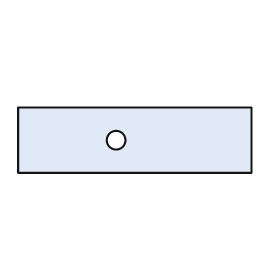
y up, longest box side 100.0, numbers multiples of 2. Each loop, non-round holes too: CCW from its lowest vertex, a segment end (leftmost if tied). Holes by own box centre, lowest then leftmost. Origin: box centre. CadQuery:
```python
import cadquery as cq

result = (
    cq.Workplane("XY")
    .moveTo(-50.0, -14.0)
    .lineTo(50.0, -14.0)
    .lineTo(50.0, 14.0)
    .lineTo(-50.0, 14.0)
    .close()
    .moveTo(-8.0, 0.0)
    .circle(4.0)
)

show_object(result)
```